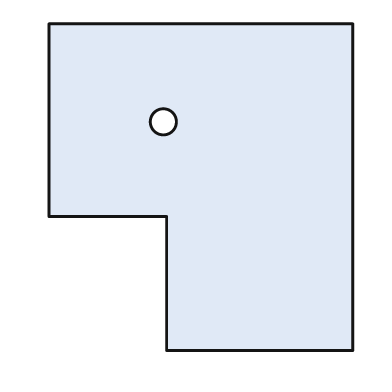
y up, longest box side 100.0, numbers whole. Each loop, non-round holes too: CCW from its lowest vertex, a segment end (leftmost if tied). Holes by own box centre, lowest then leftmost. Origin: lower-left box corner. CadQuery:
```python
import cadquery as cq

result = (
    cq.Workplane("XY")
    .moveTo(36.0, 0.0)
    .lineTo(93.0, 0.0)
    .lineTo(93.0, 100.0)
    .lineTo(0.0, 100.0)
    .lineTo(0.0, 41.0)
    .lineTo(36.0, 41.0)
    .close()
    .moveTo(35.0, 70.0)
    .circle(4.0)
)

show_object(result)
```